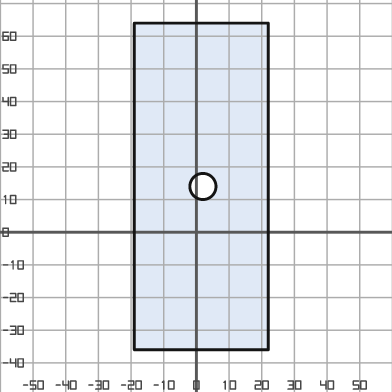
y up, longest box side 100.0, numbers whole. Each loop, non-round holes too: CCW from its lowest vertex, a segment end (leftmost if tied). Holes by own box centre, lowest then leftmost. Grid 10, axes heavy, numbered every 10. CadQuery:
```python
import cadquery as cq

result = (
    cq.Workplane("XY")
    .moveTo(-19.0, -36.0)
    .lineTo(22.0, -36.0)
    .lineTo(22.0, 64.0)
    .lineTo(-19.0, 64.0)
    .close()
    .moveTo(2.0, 14.0)
    .circle(4.0)
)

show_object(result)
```